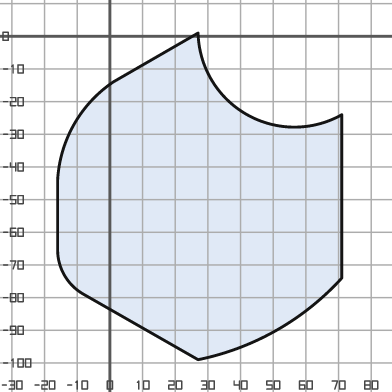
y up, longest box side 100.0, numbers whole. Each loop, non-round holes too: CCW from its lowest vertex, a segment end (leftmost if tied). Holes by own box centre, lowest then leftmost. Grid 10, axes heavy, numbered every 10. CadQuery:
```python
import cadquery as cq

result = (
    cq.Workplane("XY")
    .moveTo(27.0, -99.0)
    .threePointArc((51.0, -90.0), (71.0, -74.0))
    .lineTo(71.0, -24.0)
    .threePointArc((42.0, -24.0), (27.0, 1.0))
    .lineTo(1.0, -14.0)
    .threePointArc((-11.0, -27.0), (-16.0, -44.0))
    .lineTo(-16.0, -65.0)
    .threePointArc((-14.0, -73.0), (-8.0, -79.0))
    .close()
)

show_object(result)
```